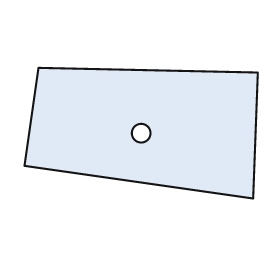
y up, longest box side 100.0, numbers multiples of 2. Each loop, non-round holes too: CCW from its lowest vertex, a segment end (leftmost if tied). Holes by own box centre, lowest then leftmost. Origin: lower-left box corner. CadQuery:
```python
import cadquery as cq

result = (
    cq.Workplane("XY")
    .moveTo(98.0, 0.0)
    .lineTo(100.0, 54.0)
    .lineTo(6.0, 56.0)
    .lineTo(0.0, 14.0)
    .close()
    .moveTo(50.0, 28.0)
    .circle(4.0)
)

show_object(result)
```